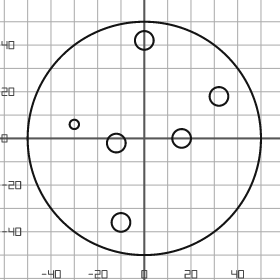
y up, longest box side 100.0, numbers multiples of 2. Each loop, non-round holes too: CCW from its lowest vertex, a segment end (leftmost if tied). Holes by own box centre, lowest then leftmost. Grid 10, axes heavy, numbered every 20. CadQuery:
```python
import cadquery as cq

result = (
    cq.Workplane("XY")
    .moveTo(0.0, 0.0)
    .circle(50.0)
    .moveTo(-10.0, -36.0)
    .circle(4.0)
    .moveTo(-12.0, -2.0)
    .circle(4.0)
    .moveTo(16.0, 0.0)
    .circle(4.0)
    .moveTo(-30.0, 6.0)
    .circle(2.0)
    .moveTo(32.0, 18.0)
    .circle(4.0)
    .moveTo(0.0, 42.0)
    .circle(4.0)
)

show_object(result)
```